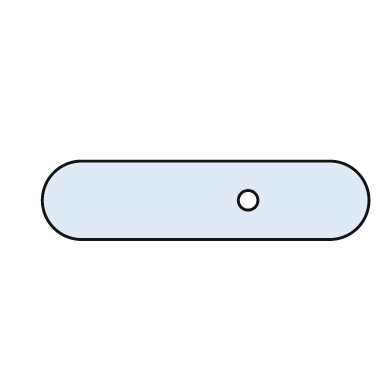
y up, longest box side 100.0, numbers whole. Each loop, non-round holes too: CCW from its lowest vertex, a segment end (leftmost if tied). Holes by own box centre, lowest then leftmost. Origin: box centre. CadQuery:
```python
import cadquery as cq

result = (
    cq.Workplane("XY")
    .moveTo(-38.0, -12.0)
    .lineTo(38.0, -12.0)
    .threePointArc((50.0, 0.0), (38.0, 12.0))
    .lineTo(-38.0, 12.0)
    .threePointArc((-50.0, 0.0), (-38.0, -12.0))
    .close()
    .moveTo(13.0, 0.0)
    .circle(3.0)
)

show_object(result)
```